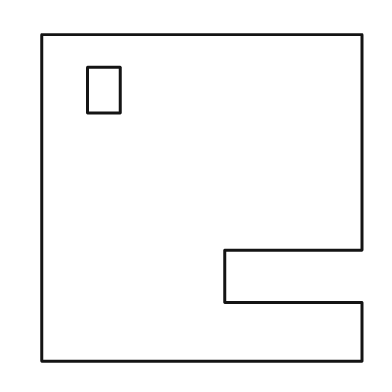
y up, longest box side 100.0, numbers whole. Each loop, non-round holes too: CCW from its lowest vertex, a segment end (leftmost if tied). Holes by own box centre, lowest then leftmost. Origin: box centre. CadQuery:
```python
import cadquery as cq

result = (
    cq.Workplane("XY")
    .moveTo(-49.0, -50.0)
    .lineTo(49.0, -50.0)
    .lineTo(49.0, -32.0)
    .lineTo(7.0, -32.0)
    .lineTo(7.0, -16.0)
    .lineTo(49.0, -16.0)
    .lineTo(49.0, 50.0)
    .lineTo(-49.0, 50.0)
    .close()
    .moveTo(-35.0, 26.0)
    .lineTo(-25.0, 26.0)
    .lineTo(-25.0, 40.0)
    .lineTo(-35.0, 40.0)
    .close()
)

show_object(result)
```